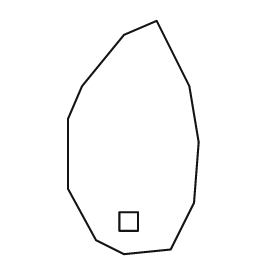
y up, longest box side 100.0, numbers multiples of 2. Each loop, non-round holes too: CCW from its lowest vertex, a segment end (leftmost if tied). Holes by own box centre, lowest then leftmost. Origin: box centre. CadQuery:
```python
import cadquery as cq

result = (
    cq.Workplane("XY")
    .moveTo(-4.0, -50.0)
    .lineTo(16.0, -48.0)
    .lineTo(26.0, -28.0)
    .lineTo(28.0, -2.0)
    .lineTo(24.0, 22.0)
    .lineTo(10.0, 50.0)
    .lineTo(-4.0, 44.0)
    .lineTo(-22.0, 22.0)
    .lineTo(-28.0, 8.0)
    .lineTo(-28.0, -22.0)
    .lineTo(-16.0, -44.0)
    .close()
    .moveTo(-6.0, -40.0)
    .lineTo(2.0, -40.0)
    .lineTo(2.0, -32.0)
    .lineTo(-6.0, -32.0)
    .close()
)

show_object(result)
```